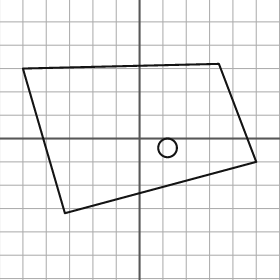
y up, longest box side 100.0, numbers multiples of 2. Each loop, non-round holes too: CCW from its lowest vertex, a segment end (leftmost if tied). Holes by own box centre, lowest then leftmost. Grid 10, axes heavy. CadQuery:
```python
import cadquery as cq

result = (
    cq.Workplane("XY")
    .moveTo(-32.0, -32.0)
    .lineTo(50.0, -10.0)
    .lineTo(34.0, 32.0)
    .lineTo(-50.0, 30.0)
    .close()
    .moveTo(12.0, -4.0)
    .circle(4.0)
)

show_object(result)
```